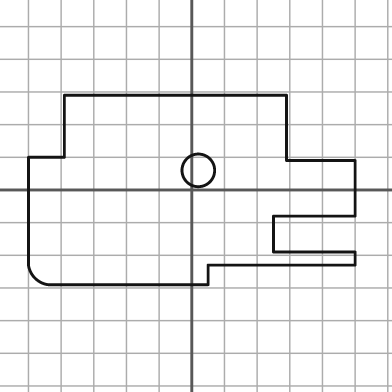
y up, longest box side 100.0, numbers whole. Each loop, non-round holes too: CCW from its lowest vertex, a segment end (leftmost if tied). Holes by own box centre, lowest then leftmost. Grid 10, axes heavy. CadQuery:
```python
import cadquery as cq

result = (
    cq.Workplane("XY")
    .moveTo(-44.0, -29.0)
    .lineTo(5.0, -29.0)
    .lineTo(5.0, -23.0)
    .lineTo(50.0, -23.0)
    .lineTo(50.0, -19.0)
    .lineTo(25.0, -19.0)
    .lineTo(25.0, -8.0)
    .lineTo(50.0, -8.0)
    .lineTo(50.0, 9.0)
    .lineTo(29.0, 9.0)
    .lineTo(29.0, 29.0)
    .lineTo(-39.0, 29.0)
    .lineTo(-39.0, 10.0)
    .lineTo(-50.0, 10.0)
    .lineTo(-50.0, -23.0)
    .threePointArc((-48.0, -27.0), (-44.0, -29.0))
    .close()
    .moveTo(2.0, 6.0)
    .circle(5.0)
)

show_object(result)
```